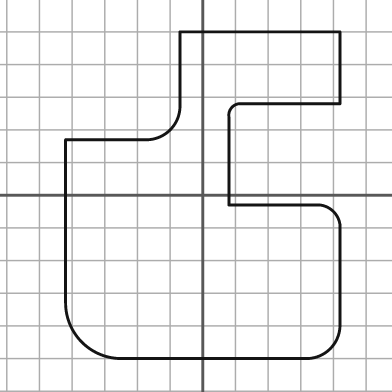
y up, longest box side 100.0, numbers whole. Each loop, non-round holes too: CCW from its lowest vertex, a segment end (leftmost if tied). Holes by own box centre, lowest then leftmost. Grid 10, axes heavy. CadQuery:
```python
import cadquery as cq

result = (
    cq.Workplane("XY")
    .moveTo(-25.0, -50.0)
    .lineTo(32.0, -50.0)
    .threePointArc((39.0, -47.0), (42.0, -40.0))
    .lineTo(42.0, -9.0)
    .threePointArc((40.0, -5.0), (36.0, -3.0))
    .lineTo(8.0, -3.0)
    .lineTo(8.0, 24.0)
    .threePointArc((9.0, 27.0), (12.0, 28.0))
    .lineTo(42.0, 28.0)
    .lineTo(42.0, 50.0)
    .lineTo(-7.0, 50.0)
    .lineTo(-7.0, 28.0)
    .threePointArc((-10.0, 20.0), (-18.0, 17.0))
    .lineTo(-42.0, 17.0)
    .lineTo(-42.0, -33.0)
    .threePointArc((-37.0, -45.0), (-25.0, -50.0))
    .close()
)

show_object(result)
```